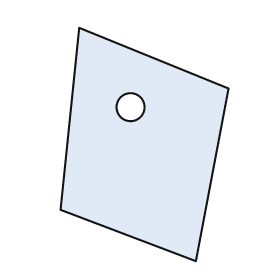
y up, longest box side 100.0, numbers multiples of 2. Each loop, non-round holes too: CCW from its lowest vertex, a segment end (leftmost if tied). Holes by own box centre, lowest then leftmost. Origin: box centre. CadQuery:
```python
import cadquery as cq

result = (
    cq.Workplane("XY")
    .moveTo(22.0, -50.0)
    .lineTo(36.0, 24.0)
    .lineTo(-28.0, 50.0)
    .lineTo(-36.0, -28.0)
    .close()
    .moveTo(-6.0, 16.0)
    .circle(6.0)
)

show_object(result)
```